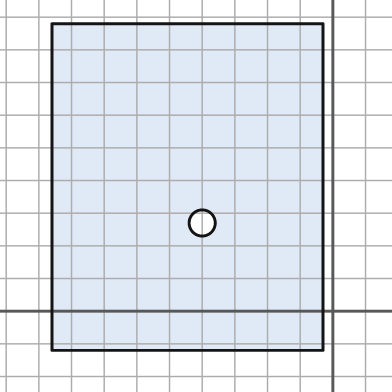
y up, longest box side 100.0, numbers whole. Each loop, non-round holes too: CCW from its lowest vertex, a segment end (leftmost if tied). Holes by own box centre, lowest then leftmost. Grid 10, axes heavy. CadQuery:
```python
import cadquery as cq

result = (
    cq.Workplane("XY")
    .moveTo(-86.0, -12.0)
    .lineTo(-3.0, -12.0)
    .lineTo(-3.0, 88.0)
    .lineTo(-86.0, 88.0)
    .close()
    .moveTo(-40.0, 27.0)
    .circle(4.0)
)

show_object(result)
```